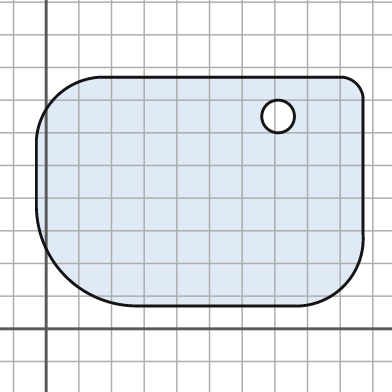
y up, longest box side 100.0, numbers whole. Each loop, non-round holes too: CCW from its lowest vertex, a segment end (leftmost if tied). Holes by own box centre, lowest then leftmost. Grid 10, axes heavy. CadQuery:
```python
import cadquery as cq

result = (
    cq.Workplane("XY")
    .moveTo(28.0, 7.0)
    .lineTo(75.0, 7.0)
    .threePointArc((91.0, 13.0), (97.0, 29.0))
    .lineTo(97.0, 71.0)
    .threePointArc((95.0, 75.0), (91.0, 77.0))
    .lineTo(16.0, 77.0)
    .threePointArc((3.0, 71.0), (-3.0, 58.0))
    .lineTo(-3.0, 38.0)
    .threePointArc((6.0, 16.0), (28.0, 7.0))
    .close()
    .moveTo(71.0, 65.0)
    .circle(5.0)
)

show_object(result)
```